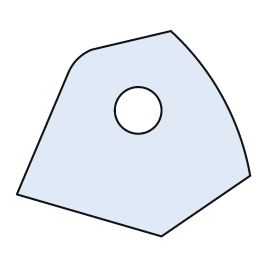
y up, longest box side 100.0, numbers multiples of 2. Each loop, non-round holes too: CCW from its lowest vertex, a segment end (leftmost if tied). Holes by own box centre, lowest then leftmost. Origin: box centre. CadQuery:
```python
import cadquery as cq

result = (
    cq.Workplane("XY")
    .moveTo(12.0, -44.0)
    .lineTo(50.0, -18.0)
    .threePointArc((38.0, 16.0), (16.0, 44.0))
    .lineTo(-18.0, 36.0)
    .threePointArc((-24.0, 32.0), (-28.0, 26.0))
    .lineTo(-50.0, -26.0)
    .close()
    .moveTo(2.0, 10.0)
    .circle(10.0)
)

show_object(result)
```